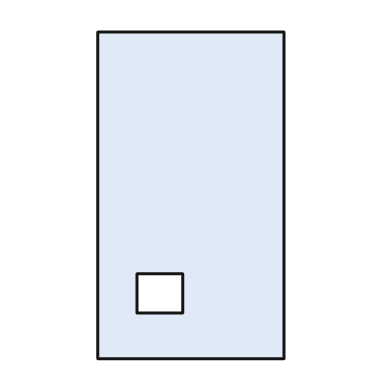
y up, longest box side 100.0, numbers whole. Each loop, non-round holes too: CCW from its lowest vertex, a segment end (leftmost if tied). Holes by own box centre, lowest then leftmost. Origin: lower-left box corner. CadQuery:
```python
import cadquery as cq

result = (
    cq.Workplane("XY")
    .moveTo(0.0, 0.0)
    .lineTo(57.0, 0.0)
    .lineTo(57.0, 100.0)
    .lineTo(0.0, 100.0)
    .close()
    .moveTo(12.0, 14.0)
    .lineTo(26.0, 14.0)
    .lineTo(26.0, 26.0)
    .lineTo(12.0, 26.0)
    .close()
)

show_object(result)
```